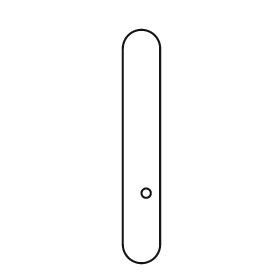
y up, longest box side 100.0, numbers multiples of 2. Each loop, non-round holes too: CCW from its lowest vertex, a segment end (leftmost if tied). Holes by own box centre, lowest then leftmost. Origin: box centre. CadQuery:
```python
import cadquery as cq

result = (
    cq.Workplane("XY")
    .moveTo(-8.0, -42.0)
    .threePointArc((0.0, -50.0), (8.0, -42.0))
    .lineTo(8.0, 42.0)
    .threePointArc((0.0, 50.0), (-8.0, 42.0))
    .close()
    .moveTo(2.0, -20.0)
    .circle(2.0)
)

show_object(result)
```